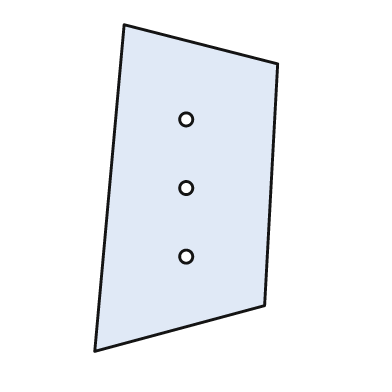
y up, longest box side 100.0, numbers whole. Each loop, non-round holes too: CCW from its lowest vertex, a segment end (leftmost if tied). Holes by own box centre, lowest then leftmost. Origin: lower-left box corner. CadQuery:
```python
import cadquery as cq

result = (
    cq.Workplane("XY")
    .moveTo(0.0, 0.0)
    .lineTo(52.0, 14.0)
    .lineTo(56.0, 88.0)
    .lineTo(9.0, 100.0)
    .close()
    .moveTo(28.0, 29.0)
    .circle(2.0)
    .moveTo(28.0, 50.0)
    .circle(2.0)
    .moveTo(28.0, 71.0)
    .circle(2.0)
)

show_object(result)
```